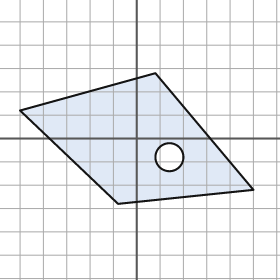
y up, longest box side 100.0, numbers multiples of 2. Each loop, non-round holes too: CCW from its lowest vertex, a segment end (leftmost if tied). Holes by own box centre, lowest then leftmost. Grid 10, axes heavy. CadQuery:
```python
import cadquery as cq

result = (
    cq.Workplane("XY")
    .moveTo(-8.0, -28.0)
    .lineTo(50.0, -22.0)
    .lineTo(8.0, 28.0)
    .lineTo(-50.0, 12.0)
    .close()
    .moveTo(14.0, -8.0)
    .circle(6.0)
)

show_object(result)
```